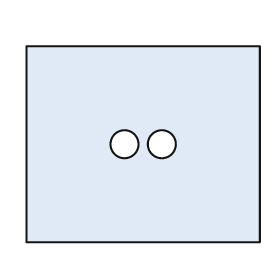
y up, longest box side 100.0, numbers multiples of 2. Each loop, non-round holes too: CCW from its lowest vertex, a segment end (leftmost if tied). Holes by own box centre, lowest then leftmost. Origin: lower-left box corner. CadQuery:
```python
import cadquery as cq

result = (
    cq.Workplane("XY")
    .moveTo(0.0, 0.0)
    .lineTo(100.0, 0.0)
    .lineTo(100.0, 84.0)
    .lineTo(0.0, 84.0)
    .close()
    .moveTo(42.0, 42.0)
    .circle(6.0)
    .moveTo(58.0, 42.0)
    .circle(6.0)
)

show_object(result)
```